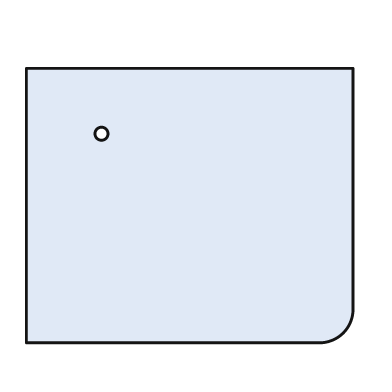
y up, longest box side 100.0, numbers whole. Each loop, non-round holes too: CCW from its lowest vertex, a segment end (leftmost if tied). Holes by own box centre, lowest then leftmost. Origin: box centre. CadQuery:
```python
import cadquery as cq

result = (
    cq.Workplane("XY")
    .moveTo(-50.0, -42.0)
    .lineTo(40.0, -42.0)
    .threePointArc((47.0, -39.0), (50.0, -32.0))
    .lineTo(50.0, 42.0)
    .lineTo(-50.0, 42.0)
    .close()
    .moveTo(-27.0, 22.0)
    .circle(2.0)
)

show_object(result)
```